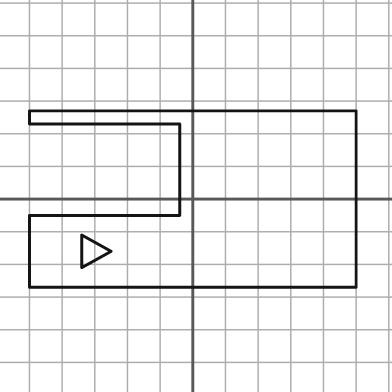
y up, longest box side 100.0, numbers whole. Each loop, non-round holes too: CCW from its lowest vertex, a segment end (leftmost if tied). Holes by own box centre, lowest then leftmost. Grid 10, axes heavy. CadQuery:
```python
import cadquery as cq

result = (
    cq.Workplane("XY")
    .moveTo(-50.0, -27.0)
    .lineTo(50.0, -27.0)
    .lineTo(50.0, 27.0)
    .lineTo(-50.0, 27.0)
    .lineTo(-50.0, 23.0)
    .lineTo(-4.0, 23.0)
    .lineTo(-4.0, -5.0)
    .lineTo(-50.0, -5.0)
    .close()
    .moveTo(-34.0, -21.0)
    .lineTo(-25.0, -16.0)
    .lineTo(-34.0, -11.0)
    .close()
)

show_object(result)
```